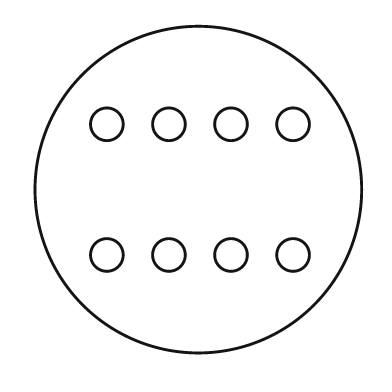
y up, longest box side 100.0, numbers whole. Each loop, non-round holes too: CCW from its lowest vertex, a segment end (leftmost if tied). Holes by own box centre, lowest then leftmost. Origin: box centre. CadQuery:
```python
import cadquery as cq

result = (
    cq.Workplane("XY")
    .moveTo(0.0, 0.0)
    .circle(50.0)
    .moveTo(-28.0, -20.0)
    .circle(5.0)
    .moveTo(-9.0, -20.0)
    .circle(5.0)
    .moveTo(10.0, -20.0)
    .circle(5.0)
    .moveTo(29.0, -20.0)
    .circle(5.0)
    .moveTo(-28.0, 20.0)
    .circle(5.0)
    .moveTo(-9.0, 20.0)
    .circle(5.0)
    .moveTo(10.0, 20.0)
    .circle(5.0)
    .moveTo(29.0, 20.0)
    .circle(5.0)
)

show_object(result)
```